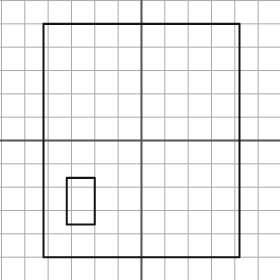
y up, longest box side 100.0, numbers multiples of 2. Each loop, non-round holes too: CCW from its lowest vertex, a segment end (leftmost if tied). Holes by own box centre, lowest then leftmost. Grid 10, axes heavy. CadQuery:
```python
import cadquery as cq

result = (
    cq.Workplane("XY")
    .moveTo(-42.0, -50.0)
    .lineTo(42.0, -50.0)
    .lineTo(42.0, 50.0)
    .lineTo(-42.0, 50.0)
    .close()
    .moveTo(-32.0, -36.0)
    .lineTo(-20.0, -36.0)
    .lineTo(-20.0, -16.0)
    .lineTo(-32.0, -16.0)
    .close()
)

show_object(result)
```